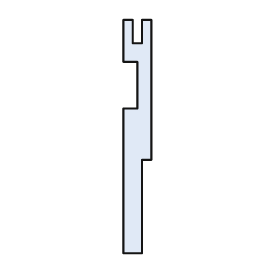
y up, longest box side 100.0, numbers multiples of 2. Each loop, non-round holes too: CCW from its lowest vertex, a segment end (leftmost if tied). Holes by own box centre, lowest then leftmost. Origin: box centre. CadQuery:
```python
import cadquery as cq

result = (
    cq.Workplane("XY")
    .moveTo(-6.0, -50.0)
    .lineTo(2.0, -50.0)
    .lineTo(2.0, -10.0)
    .lineTo(6.0, -10.0)
    .lineTo(6.0, 50.0)
    .lineTo(2.0, 50.0)
    .lineTo(2.0, 40.0)
    .lineTo(-2.0, 40.0)
    .lineTo(-2.0, 50.0)
    .lineTo(-6.0, 50.0)
    .lineTo(-6.0, 32.0)
    .lineTo(0.0, 32.0)
    .lineTo(0.0, 12.0)
    .lineTo(-6.0, 12.0)
    .close()
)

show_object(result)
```